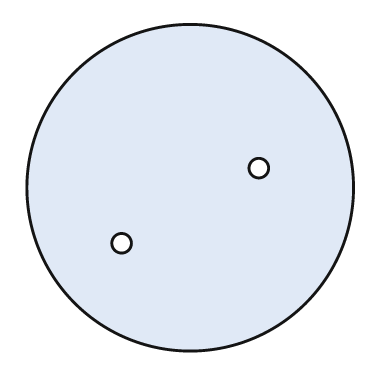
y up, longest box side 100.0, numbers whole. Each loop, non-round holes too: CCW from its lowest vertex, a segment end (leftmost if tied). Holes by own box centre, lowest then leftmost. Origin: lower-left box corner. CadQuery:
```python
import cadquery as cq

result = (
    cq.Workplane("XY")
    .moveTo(50.0, 50.0)
    .circle(50.0)
    .moveTo(29.0, 33.0)
    .circle(3.0)
    .moveTo(71.0, 56.0)
    .circle(3.0)
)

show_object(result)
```